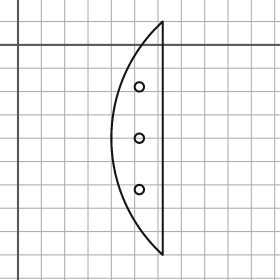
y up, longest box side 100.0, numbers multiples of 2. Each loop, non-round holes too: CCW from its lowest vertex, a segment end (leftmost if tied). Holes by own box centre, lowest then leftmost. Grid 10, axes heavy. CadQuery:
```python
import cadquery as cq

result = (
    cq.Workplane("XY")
    .moveTo(62.0, -90.0)
    .lineTo(62.0, 10.0)
    .threePointArc((40.0, -40.0), (62.0, -90.0))
    .close()
    .moveTo(52.0, -62.0)
    .circle(2.0)
    .moveTo(52.0, -40.0)
    .circle(2.0)
    .moveTo(52.0, -18.0)
    .circle(2.0)
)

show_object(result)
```